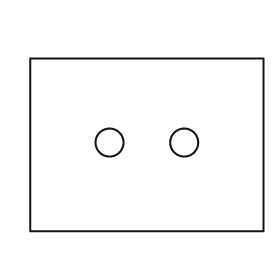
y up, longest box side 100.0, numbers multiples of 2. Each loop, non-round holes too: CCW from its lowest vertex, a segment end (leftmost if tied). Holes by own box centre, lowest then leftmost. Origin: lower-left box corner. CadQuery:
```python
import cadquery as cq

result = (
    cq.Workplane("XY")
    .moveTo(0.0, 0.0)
    .lineTo(100.0, 0.0)
    .lineTo(100.0, 74.0)
    .lineTo(0.0, 74.0)
    .close()
    .moveTo(34.0, 38.0)
    .circle(6.0)
    .moveTo(66.0, 38.0)
    .circle(6.0)
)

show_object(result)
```